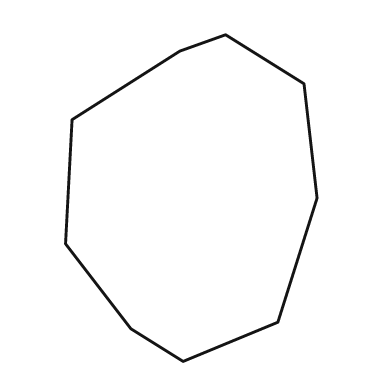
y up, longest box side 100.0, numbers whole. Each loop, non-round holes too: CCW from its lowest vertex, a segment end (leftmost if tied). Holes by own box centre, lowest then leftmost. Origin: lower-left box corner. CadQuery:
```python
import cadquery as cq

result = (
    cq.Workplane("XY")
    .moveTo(36.0, 0.0)
    .lineTo(65.0, 12.0)
    .lineTo(77.0, 50.0)
    .lineTo(73.0, 85.0)
    .lineTo(49.0, 100.0)
    .lineTo(35.0, 95.0)
    .lineTo(2.0, 74.0)
    .lineTo(0.0, 36.0)
    .lineTo(20.0, 10.0)
    .close()
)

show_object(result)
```